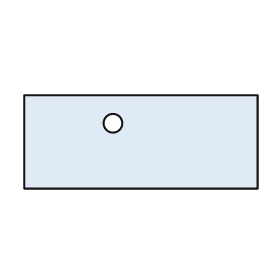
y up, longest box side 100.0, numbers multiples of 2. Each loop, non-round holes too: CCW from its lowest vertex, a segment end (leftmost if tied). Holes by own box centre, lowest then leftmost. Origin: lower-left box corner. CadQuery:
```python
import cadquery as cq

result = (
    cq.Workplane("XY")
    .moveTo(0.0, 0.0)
    .lineTo(100.0, 0.0)
    .lineTo(100.0, 40.0)
    .lineTo(0.0, 40.0)
    .close()
    .moveTo(38.0, 28.0)
    .circle(4.0)
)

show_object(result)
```